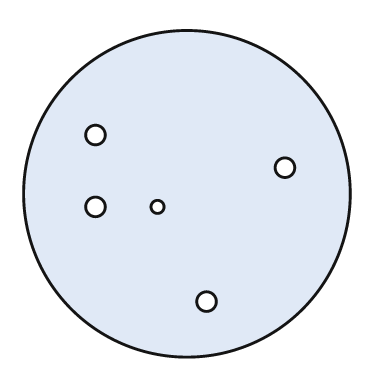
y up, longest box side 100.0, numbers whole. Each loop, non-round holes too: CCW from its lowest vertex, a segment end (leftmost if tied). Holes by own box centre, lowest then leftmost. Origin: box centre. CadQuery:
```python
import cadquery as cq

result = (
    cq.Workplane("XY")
    .moveTo(0.0, 0.0)
    .circle(50.0)
    .moveTo(6.0, -33.0)
    .circle(3.0)
    .moveTo(-28.0, -4.0)
    .circle(3.0)
    .moveTo(-9.0, -4.0)
    .circle(2.0)
    .moveTo(30.0, 8.0)
    .circle(3.0)
    .moveTo(-28.0, 18.0)
    .circle(3.0)
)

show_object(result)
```